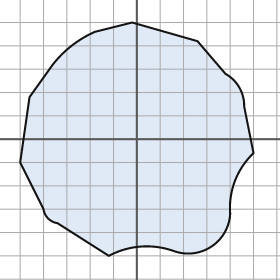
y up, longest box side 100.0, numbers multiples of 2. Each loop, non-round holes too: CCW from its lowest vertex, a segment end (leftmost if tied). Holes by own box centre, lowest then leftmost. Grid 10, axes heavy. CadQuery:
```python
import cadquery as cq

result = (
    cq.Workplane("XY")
    .moveTo(-12.0, -50.0)
    .threePointArc((2.0, -46.0), (16.0, -48.0))
    .threePointArc((32.0, -46.0), (40.0, -32.0))
    .threePointArc((42.0, -18.0), (50.0, -6.0))
    .lineTo(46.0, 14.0)
    .threePointArc((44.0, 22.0), (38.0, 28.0))
    .lineTo(26.0, 42.0)
    .lineTo(-2.0, 50.0)
    .lineTo(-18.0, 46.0)
    .threePointArc((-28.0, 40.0), (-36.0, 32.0))
    .lineTo(-46.0, 18.0)
    .lineTo(-50.0, -10.0)
    .lineTo(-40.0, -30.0)
    .threePointArc((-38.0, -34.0), (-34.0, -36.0))
    .close()
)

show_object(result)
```